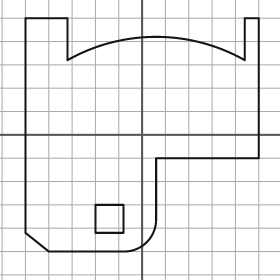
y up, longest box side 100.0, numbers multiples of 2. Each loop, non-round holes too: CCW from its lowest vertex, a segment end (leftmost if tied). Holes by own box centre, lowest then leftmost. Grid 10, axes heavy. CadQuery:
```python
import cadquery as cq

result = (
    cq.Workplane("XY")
    .moveTo(-40.0, -50.0)
    .lineTo(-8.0, -50.0)
    .threePointArc((2.0, -46.0), (6.0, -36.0))
    .lineTo(6.0, -10.0)
    .lineTo(50.0, -10.0)
    .lineTo(50.0, 50.0)
    .lineTo(44.0, 50.0)
    .lineTo(44.0, 32.0)
    .threePointArc((6.0, 42.0), (-32.0, 32.0))
    .lineTo(-32.0, 50.0)
    .lineTo(-50.0, 50.0)
    .lineTo(-50.0, -42.0)
    .close()
    .moveTo(-20.0, -42.0)
    .lineTo(-8.0, -42.0)
    .lineTo(-8.0, -30.0)
    .lineTo(-20.0, -30.0)
    .close()
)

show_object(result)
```